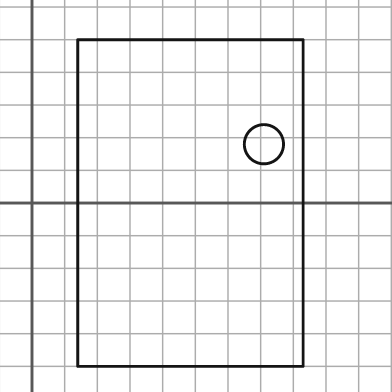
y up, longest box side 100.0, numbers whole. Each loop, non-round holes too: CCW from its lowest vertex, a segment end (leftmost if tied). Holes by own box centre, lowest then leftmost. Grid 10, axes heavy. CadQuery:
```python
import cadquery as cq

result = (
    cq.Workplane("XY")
    .moveTo(14.0, -50.0)
    .lineTo(83.0, -50.0)
    .lineTo(83.0, 50.0)
    .lineTo(14.0, 50.0)
    .close()
    .moveTo(71.0, 18.0)
    .circle(6.0)
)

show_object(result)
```